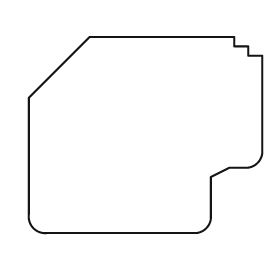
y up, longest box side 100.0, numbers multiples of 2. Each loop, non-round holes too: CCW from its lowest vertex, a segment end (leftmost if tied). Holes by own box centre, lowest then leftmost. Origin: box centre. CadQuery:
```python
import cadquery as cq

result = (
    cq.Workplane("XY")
    .moveTo(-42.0, -42.0)
    .lineTo(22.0, -42.0)
    .threePointArc((26.0, -40.0), (28.0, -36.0))
    .lineTo(28.0, -18.0)
    .lineTo(36.0, -14.0)
    .lineTo(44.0, -14.0)
    .threePointArc((48.0, -12.0), (50.0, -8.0))
    .lineTo(50.0, 34.0)
    .lineTo(44.0, 34.0)
    .lineTo(44.0, 38.0)
    .lineTo(38.0, 38.0)
    .lineTo(38.0, 42.0)
    .lineTo(-24.0, 42.0)
    .lineTo(-50.0, 16.0)
    .lineTo(-50.0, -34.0)
    .threePointArc((-48.0, -40.0), (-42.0, -42.0))
    .close()
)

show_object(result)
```